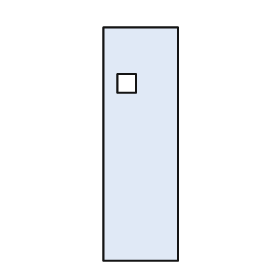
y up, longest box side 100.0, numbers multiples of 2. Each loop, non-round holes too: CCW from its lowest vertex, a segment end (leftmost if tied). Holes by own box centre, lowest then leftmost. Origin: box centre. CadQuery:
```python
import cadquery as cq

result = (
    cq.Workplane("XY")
    .moveTo(-16.0, -50.0)
    .lineTo(16.0, -50.0)
    .lineTo(16.0, 50.0)
    .lineTo(-16.0, 50.0)
    .close()
    .moveTo(-10.0, 22.0)
    .lineTo(-2.0, 22.0)
    .lineTo(-2.0, 30.0)
    .lineTo(-10.0, 30.0)
    .close()
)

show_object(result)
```